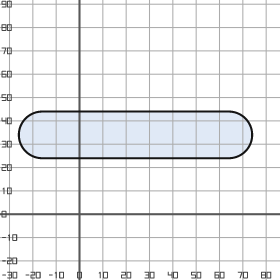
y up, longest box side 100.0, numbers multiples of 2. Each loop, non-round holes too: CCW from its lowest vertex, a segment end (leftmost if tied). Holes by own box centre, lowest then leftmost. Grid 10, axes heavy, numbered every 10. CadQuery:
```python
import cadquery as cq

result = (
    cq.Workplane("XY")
    .moveTo(-16.0, 24.0)
    .lineTo(64.0, 24.0)
    .threePointArc((74.0, 34.0), (64.0, 44.0))
    .lineTo(-16.0, 44.0)
    .threePointArc((-26.0, 34.0), (-16.0, 24.0))
    .close()
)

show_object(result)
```